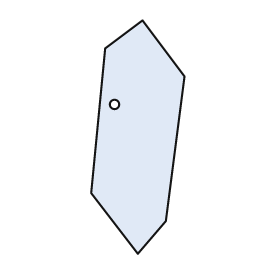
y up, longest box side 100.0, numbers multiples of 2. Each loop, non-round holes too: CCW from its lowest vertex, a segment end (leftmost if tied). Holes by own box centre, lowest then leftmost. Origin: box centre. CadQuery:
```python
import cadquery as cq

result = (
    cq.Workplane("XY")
    .moveTo(0.0, -50.0)
    .lineTo(12.0, -36.0)
    .lineTo(20.0, 26.0)
    .lineTo(2.0, 50.0)
    .lineTo(-14.0, 38.0)
    .lineTo(-20.0, -24.0)
    .close()
    .moveTo(-10.0, 14.0)
    .circle(2.0)
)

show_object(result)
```